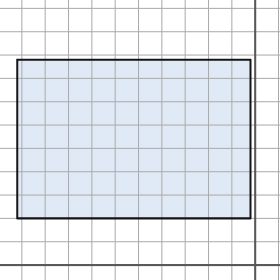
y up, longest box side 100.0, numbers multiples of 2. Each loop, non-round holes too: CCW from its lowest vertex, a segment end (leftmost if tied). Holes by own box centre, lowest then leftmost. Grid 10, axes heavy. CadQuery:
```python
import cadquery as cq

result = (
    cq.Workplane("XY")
    .moveTo(-102.0, 20.0)
    .lineTo(-2.0, 20.0)
    .lineTo(-2.0, 88.0)
    .lineTo(-102.0, 88.0)
    .close()
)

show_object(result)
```